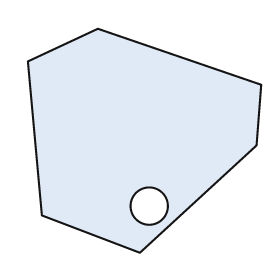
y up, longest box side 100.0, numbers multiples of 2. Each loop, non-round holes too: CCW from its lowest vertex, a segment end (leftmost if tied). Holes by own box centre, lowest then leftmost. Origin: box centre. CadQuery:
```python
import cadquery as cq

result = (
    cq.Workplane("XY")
    .moveTo(-2.0, -48.0)
    .lineTo(48.0, -2.0)
    .lineTo(50.0, 24.0)
    .lineTo(-20.0, 48.0)
    .lineTo(-50.0, 34.0)
    .lineTo(-44.0, -32.0)
    .close()
    .moveTo(2.0, -28.0)
    .circle(8.0)
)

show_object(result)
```